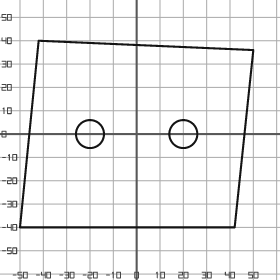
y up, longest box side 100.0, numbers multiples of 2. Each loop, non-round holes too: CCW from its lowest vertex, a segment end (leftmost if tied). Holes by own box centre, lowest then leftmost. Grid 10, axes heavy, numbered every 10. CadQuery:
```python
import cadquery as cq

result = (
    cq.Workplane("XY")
    .moveTo(-50.0, -40.0)
    .lineTo(42.0, -40.0)
    .lineTo(50.0, 36.0)
    .lineTo(-42.0, 40.0)
    .close()
    .moveTo(-20.0, 0.0)
    .circle(6.0)
    .moveTo(20.0, 0.0)
    .circle(6.0)
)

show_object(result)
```